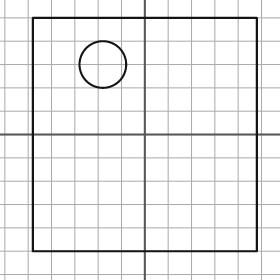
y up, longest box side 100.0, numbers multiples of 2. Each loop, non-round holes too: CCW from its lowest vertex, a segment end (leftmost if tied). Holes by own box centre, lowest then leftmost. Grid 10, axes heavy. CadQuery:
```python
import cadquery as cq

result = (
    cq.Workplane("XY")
    .moveTo(-48.0, -50.0)
    .lineTo(48.0, -50.0)
    .lineTo(48.0, 50.0)
    .lineTo(-48.0, 50.0)
    .close()
    .moveTo(-18.0, 30.0)
    .circle(10.0)
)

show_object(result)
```